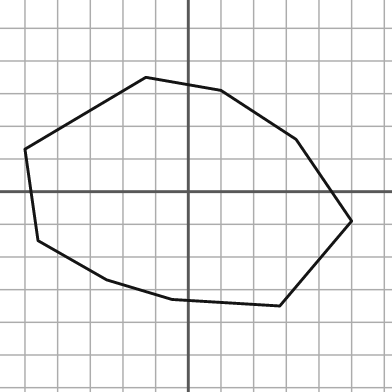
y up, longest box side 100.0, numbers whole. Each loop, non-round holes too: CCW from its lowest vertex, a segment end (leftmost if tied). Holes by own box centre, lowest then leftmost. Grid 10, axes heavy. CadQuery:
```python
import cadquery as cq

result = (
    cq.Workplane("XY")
    .moveTo(28.0, -35.0)
    .lineTo(50.0, -9.0)
    .lineTo(33.0, 16.0)
    .lineTo(10.0, 31.0)
    .lineTo(-13.0, 35.0)
    .lineTo(-50.0, 13.0)
    .lineTo(-46.0, -15.0)
    .lineTo(-25.0, -27.0)
    .lineTo(-5.0, -33.0)
    .close()
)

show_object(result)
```